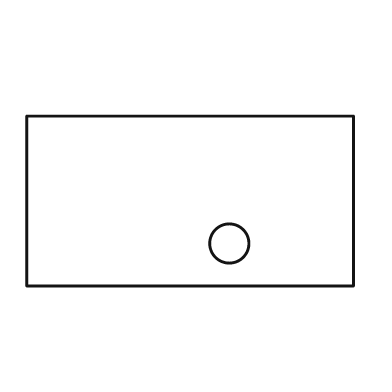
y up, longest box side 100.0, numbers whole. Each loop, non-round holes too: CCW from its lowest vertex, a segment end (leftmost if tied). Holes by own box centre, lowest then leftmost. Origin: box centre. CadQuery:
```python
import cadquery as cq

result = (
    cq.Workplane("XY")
    .moveTo(-50.0, -26.0)
    .lineTo(50.0, -26.0)
    .lineTo(50.0, 26.0)
    .lineTo(-50.0, 26.0)
    .close()
    .moveTo(12.0, -13.0)
    .circle(6.0)
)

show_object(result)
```